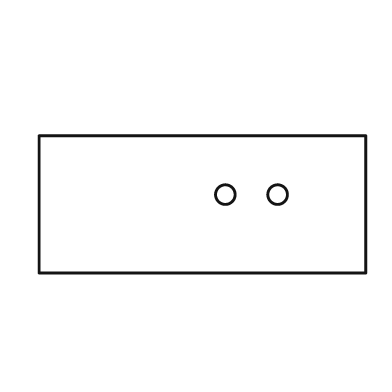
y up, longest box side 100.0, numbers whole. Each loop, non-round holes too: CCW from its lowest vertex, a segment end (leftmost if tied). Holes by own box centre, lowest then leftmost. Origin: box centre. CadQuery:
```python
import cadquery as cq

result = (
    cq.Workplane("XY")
    .moveTo(-50.0, -21.0)
    .lineTo(50.0, -21.0)
    .lineTo(50.0, 21.0)
    .lineTo(-50.0, 21.0)
    .close()
    .moveTo(7.0, 3.0)
    .circle(3.0)
    .moveTo(23.0, 3.0)
    .circle(3.0)
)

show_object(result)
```